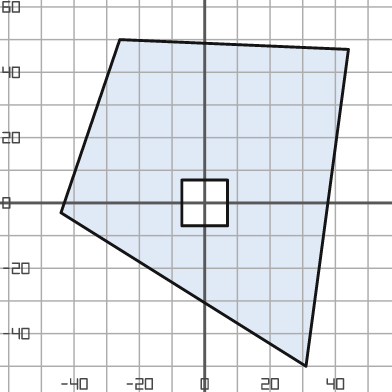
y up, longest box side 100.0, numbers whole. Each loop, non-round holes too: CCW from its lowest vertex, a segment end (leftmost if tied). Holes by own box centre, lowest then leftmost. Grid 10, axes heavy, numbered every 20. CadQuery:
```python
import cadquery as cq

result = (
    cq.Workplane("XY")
    .moveTo(31.0, -50.0)
    .lineTo(44.0, 47.0)
    .lineTo(-26.0, 50.0)
    .lineTo(-44.0, -3.0)
    .close()
    .moveTo(-7.0, -7.0)
    .lineTo(7.0, -7.0)
    .lineTo(7.0, 7.0)
    .lineTo(-7.0, 7.0)
    .close()
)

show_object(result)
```